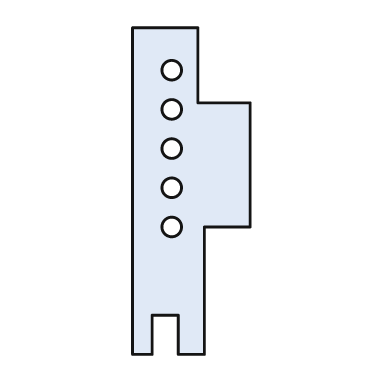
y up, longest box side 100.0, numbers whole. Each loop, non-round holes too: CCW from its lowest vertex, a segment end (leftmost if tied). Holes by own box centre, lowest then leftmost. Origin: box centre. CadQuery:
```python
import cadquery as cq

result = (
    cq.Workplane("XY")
    .moveTo(-18.0, -50.0)
    .lineTo(-12.0, -50.0)
    .lineTo(-12.0, -38.0)
    .lineTo(-4.0, -38.0)
    .lineTo(-4.0, -50.0)
    .lineTo(4.0, -50.0)
    .lineTo(4.0, -11.0)
    .lineTo(18.0, -11.0)
    .lineTo(18.0, 27.0)
    .lineTo(2.0, 27.0)
    .lineTo(2.0, 50.0)
    .lineTo(-18.0, 50.0)
    .close()
    .moveTo(-6.0, -11.0)
    .circle(3.0)
    .moveTo(-6.0, 1.0)
    .circle(3.0)
    .moveTo(-6.0, 13.0)
    .circle(3.0)
    .moveTo(-6.0, 25.0)
    .circle(3.0)
    .moveTo(-6.0, 37.0)
    .circle(3.0)
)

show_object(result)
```